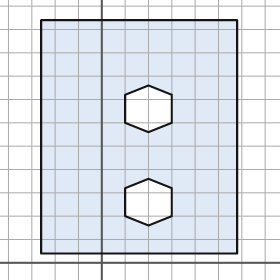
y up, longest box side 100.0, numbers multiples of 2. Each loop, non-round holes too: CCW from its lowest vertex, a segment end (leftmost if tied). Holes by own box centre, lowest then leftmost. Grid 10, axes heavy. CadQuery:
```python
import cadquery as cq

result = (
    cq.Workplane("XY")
    .moveTo(-26.0, 4.0)
    .lineTo(58.0, 4.0)
    .lineTo(58.0, 104.0)
    .lineTo(-26.0, 104.0)
    .close()
    .moveTo(20.0, 16.0)
    .lineTo(30.0, 20.0)
    .lineTo(30.0, 32.0)
    .lineTo(20.0, 36.0)
    .lineTo(10.0, 32.0)
    .lineTo(10.0, 20.0)
    .close()
    .moveTo(20.0, 56.0)
    .lineTo(30.0, 60.0)
    .lineTo(30.0, 72.0)
    .lineTo(20.0, 76.0)
    .lineTo(10.0, 72.0)
    .lineTo(10.0, 60.0)
    .close()
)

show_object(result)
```